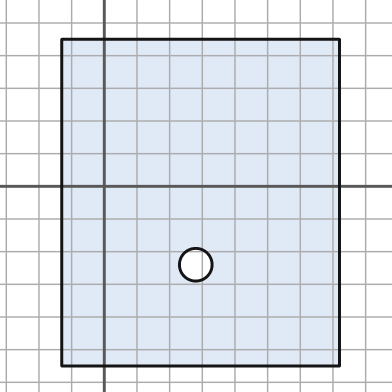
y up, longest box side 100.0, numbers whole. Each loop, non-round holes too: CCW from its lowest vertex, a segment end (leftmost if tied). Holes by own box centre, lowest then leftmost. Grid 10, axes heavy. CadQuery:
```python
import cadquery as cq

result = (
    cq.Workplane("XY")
    .moveTo(-13.0, -55.0)
    .lineTo(72.0, -55.0)
    .lineTo(72.0, 45.0)
    .lineTo(-13.0, 45.0)
    .close()
    .moveTo(28.0, -24.0)
    .circle(5.0)
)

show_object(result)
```